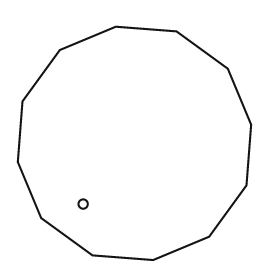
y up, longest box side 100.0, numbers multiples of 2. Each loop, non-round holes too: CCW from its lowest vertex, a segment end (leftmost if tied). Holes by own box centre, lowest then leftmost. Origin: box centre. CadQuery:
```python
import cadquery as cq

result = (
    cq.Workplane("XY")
    .moveTo(8.0, -50.0)
    .lineTo(32.0, -40.0)
    .lineTo(48.0, -18.0)
    .lineTo(50.0, 8.0)
    .lineTo(40.0, 32.0)
    .lineTo(18.0, 48.0)
    .lineTo(-8.0, 50.0)
    .lineTo(-32.0, 40.0)
    .lineTo(-48.0, 18.0)
    .lineTo(-50.0, -8.0)
    .lineTo(-40.0, -32.0)
    .lineTo(-18.0, -48.0)
    .close()
    .moveTo(-22.0, -26.0)
    .circle(2.0)
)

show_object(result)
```